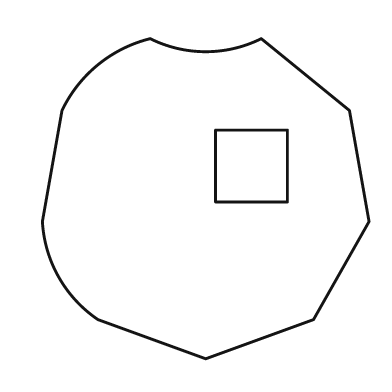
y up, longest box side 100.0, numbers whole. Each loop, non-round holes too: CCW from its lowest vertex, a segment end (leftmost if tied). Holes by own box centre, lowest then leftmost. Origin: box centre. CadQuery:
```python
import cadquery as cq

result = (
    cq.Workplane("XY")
    .moveTo(0.0, -49.0)
    .lineTo(33.0, -37.0)
    .lineTo(50.0, -7.0)
    .lineTo(44.0, 27.0)
    .lineTo(17.0, 49.0)
    .threePointArc((0.0, 45.0), (-17.0, 49.0))
    .threePointArc((-33.0, 41.0), (-44.0, 27.0))
    .lineTo(-50.0, -7.0)
    .threePointArc((-45.0, -24.0), (-33.0, -37.0))
    .close()
    .moveTo(3.0, -1.0)
    .lineTo(25.0, -1.0)
    .lineTo(25.0, 21.0)
    .lineTo(3.0, 21.0)
    .close()
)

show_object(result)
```